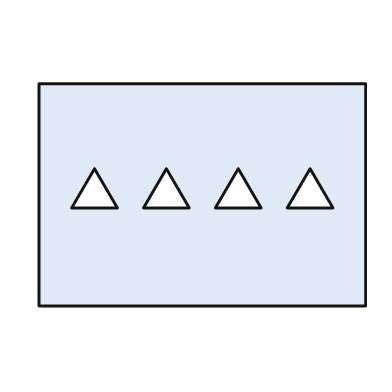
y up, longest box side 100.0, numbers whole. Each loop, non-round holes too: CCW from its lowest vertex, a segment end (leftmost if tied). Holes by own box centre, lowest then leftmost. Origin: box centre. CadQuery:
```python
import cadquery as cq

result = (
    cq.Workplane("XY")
    .moveTo(-50.0, -34.0)
    .lineTo(50.0, -34.0)
    .lineTo(50.0, 34.0)
    .lineTo(-50.0, 34.0)
    .close()
    .moveTo(-40.0, -4.0)
    .lineTo(-26.0, -4.0)
    .lineTo(-33.0, 8.0)
    .close()
    .moveTo(-18.0, -4.0)
    .lineTo(-4.0, -4.0)
    .lineTo(-11.0, 8.0)
    .close()
    .moveTo(4.0, -4.0)
    .lineTo(18.0, -4.0)
    .lineTo(11.0, 8.0)
    .close()
    .moveTo(26.0, -4.0)
    .lineTo(40.0, -4.0)
    .lineTo(33.0, 8.0)
    .close()
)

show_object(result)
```